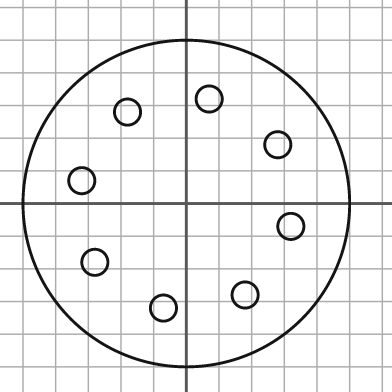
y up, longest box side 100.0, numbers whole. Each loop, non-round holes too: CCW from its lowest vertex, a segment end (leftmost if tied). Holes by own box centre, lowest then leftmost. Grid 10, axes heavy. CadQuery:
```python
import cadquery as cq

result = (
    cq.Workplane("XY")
    .moveTo(0.0, 0.0)
    .circle(50.0)
    .moveTo(-7.0, -32.0)
    .circle(4.0)
    .moveTo(18.0, -28.0)
    .circle(4.0)
    .moveTo(-28.0, -18.0)
    .circle(4.0)
    .moveTo(32.0, -7.0)
    .circle(4.0)
    .moveTo(-32.0, 7.0)
    .circle(4.0)
    .moveTo(28.0, 18.0)
    .circle(4.0)
    .moveTo(-18.0, 28.0)
    .circle(4.0)
    .moveTo(7.0, 32.0)
    .circle(4.0)
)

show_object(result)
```